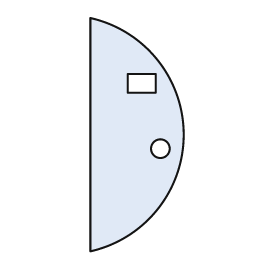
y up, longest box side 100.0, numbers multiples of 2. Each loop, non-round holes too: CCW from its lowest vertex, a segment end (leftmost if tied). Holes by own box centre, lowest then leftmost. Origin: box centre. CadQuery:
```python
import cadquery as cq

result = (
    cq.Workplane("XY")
    .moveTo(-20.0, -50.0)
    .threePointArc((20.0, 0.0), (-20.0, 50.0))
    .close()
    .moveTo(10.0, -6.0)
    .circle(4.0)
    .moveTo(-4.0, 18.0)
    .lineTo(8.0, 18.0)
    .lineTo(8.0, 26.0)
    .lineTo(-4.0, 26.0)
    .close()
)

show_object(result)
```